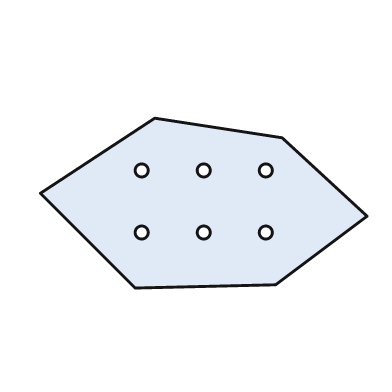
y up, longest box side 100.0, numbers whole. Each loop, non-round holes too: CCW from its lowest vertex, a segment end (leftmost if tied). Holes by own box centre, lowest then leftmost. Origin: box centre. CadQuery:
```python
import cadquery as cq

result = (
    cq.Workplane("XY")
    .moveTo(-21.0, -26.0)
    .lineTo(22.0, -25.0)
    .lineTo(50.0, -4.0)
    .lineTo(24.0, 20.0)
    .lineTo(-15.0, 26.0)
    .lineTo(-50.0, 3.0)
    .close()
    .moveTo(-19.0, -9.0)
    .circle(2.0)
    .moveTo(0.0, -9.0)
    .circle(2.0)
    .moveTo(19.0, -9.0)
    .circle(2.0)
    .moveTo(-19.0, 10.0)
    .circle(2.0)
    .moveTo(0.0, 10.0)
    .circle(2.0)
    .moveTo(19.0, 10.0)
    .circle(2.0)
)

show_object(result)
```